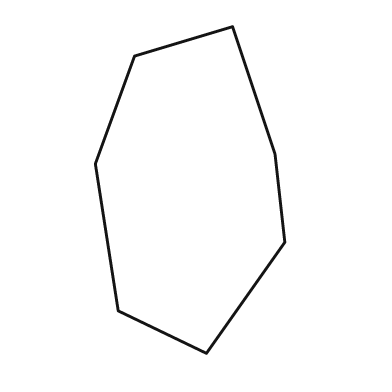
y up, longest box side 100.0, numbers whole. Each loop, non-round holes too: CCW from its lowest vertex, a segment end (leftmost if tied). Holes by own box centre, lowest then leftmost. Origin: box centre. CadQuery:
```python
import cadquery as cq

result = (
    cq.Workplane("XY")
    .moveTo(5.0, -50.0)
    .lineTo(29.0, -16.0)
    .lineTo(26.0, 11.0)
    .lineTo(13.0, 50.0)
    .lineTo(-17.0, 41.0)
    .lineTo(-29.0, 8.0)
    .lineTo(-22.0, -37.0)
    .close()
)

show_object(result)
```